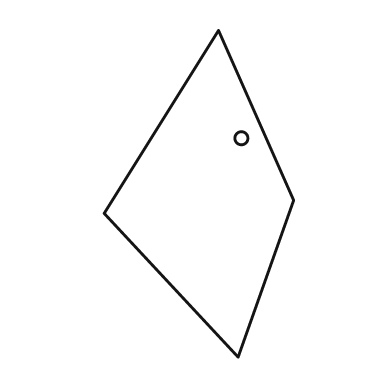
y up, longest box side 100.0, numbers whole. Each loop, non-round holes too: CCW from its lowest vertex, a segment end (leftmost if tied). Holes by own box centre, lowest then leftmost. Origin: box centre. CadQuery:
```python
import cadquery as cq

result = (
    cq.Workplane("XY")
    .moveTo(12.0, -50.0)
    .lineTo(29.0, -2.0)
    .lineTo(6.0, 50.0)
    .lineTo(-29.0, -6.0)
    .close()
    .moveTo(13.0, 17.0)
    .circle(2.0)
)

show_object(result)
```